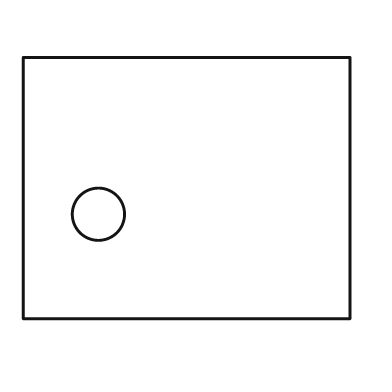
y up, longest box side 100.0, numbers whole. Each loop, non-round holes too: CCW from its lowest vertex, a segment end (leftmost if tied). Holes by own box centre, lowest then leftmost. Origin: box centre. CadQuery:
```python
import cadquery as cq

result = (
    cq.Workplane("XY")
    .moveTo(-50.0, -40.0)
    .lineTo(50.0, -40.0)
    .lineTo(50.0, 40.0)
    .lineTo(-50.0, 40.0)
    .close()
    .moveTo(-27.0, -8.0)
    .circle(8.0)
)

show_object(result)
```